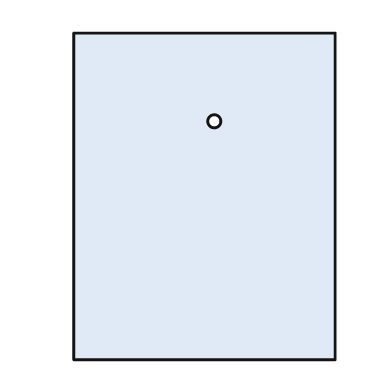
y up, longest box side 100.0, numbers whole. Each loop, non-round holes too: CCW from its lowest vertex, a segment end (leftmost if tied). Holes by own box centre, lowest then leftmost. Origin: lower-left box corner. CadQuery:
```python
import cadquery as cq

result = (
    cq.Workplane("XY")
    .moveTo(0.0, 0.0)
    .lineTo(80.0, 0.0)
    .lineTo(80.0, 100.0)
    .lineTo(0.0, 100.0)
    .close()
    .moveTo(43.0, 73.0)
    .circle(2.0)
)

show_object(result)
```